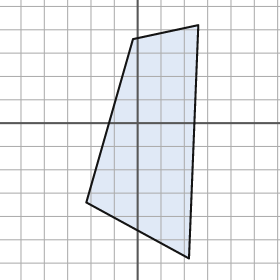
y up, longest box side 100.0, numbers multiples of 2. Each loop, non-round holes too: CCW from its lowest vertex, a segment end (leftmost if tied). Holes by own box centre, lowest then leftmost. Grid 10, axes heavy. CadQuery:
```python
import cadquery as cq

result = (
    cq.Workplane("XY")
    .moveTo(22.0, -58.0)
    .lineTo(26.0, 42.0)
    .lineTo(-2.0, 36.0)
    .lineTo(-22.0, -34.0)
    .close()
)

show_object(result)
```